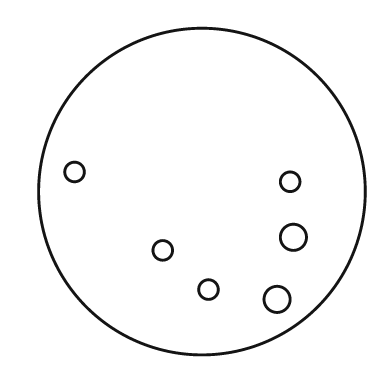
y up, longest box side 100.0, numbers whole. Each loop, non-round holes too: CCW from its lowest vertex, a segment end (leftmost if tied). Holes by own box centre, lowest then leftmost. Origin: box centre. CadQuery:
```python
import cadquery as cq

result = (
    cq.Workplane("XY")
    .moveTo(0.0, 0.0)
    .circle(50.0)
    .moveTo(23.0, -33.0)
    .circle(4.0)
    .moveTo(2.0, -30.0)
    .circle(3.0)
    .moveTo(-12.0, -18.0)
    .circle(3.0)
    .moveTo(28.0, -14.0)
    .circle(4.0)
    .moveTo(27.0, 3.0)
    .circle(3.0)
    .moveTo(-39.0, 6.0)
    .circle(3.0)
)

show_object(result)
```